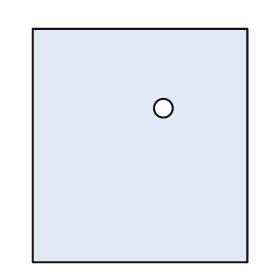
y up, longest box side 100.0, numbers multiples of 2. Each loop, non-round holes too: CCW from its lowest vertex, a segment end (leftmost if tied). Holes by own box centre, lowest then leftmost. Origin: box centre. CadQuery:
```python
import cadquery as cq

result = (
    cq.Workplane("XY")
    .moveTo(-46.0, -50.0)
    .lineTo(46.0, -50.0)
    .lineTo(46.0, 50.0)
    .lineTo(-46.0, 50.0)
    .close()
    .moveTo(10.0, 16.0)
    .circle(4.0)
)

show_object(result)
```